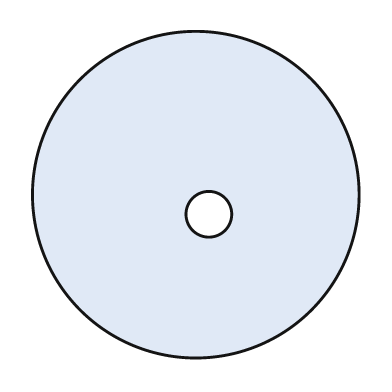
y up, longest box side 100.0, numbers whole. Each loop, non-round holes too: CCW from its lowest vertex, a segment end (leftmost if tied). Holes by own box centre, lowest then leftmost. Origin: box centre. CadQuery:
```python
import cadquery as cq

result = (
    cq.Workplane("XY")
    .moveTo(0.0, 0.0)
    .circle(50.0)
    .moveTo(4.0, -6.0)
    .circle(7.0)
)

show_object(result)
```